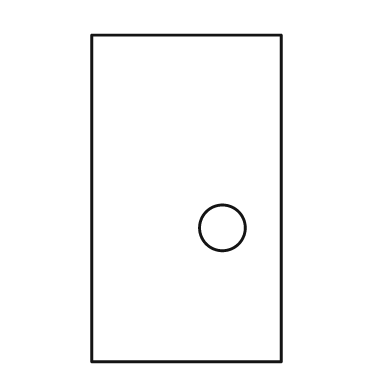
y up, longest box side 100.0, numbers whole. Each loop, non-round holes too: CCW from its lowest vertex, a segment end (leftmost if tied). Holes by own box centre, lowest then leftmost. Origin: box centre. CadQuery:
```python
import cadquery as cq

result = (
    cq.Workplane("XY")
    .moveTo(-29.0, -50.0)
    .lineTo(29.0, -50.0)
    .lineTo(29.0, 50.0)
    .lineTo(-29.0, 50.0)
    .close()
    .moveTo(11.0, -9.0)
    .circle(7.0)
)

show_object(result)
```